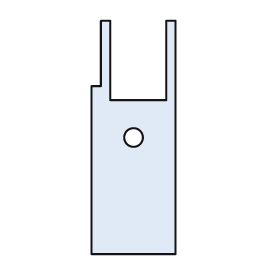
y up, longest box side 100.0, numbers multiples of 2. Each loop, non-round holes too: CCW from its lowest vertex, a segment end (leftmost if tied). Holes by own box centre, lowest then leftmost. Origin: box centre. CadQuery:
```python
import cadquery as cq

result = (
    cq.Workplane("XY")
    .moveTo(-18.0, -50.0)
    .lineTo(18.0, -50.0)
    .lineTo(18.0, 50.0)
    .lineTo(14.0, 50.0)
    .lineTo(14.0, 16.0)
    .lineTo(-10.0, 16.0)
    .lineTo(-10.0, 50.0)
    .lineTo(-14.0, 50.0)
    .lineTo(-14.0, 22.0)
    .lineTo(-18.0, 22.0)
    .close()
    .moveTo(0.0, 0.0)
    .circle(4.0)
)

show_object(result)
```